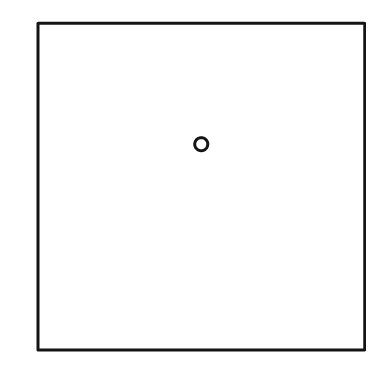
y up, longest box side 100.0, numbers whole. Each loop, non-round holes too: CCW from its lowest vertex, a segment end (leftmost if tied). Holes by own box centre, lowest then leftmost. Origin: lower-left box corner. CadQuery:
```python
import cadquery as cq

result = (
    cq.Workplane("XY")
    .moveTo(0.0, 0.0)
    .lineTo(100.0, 0.0)
    .lineTo(100.0, 100.0)
    .lineTo(0.0, 100.0)
    .close()
    .moveTo(50.0, 63.0)
    .circle(2.0)
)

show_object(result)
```